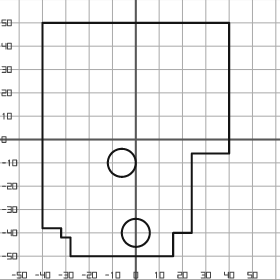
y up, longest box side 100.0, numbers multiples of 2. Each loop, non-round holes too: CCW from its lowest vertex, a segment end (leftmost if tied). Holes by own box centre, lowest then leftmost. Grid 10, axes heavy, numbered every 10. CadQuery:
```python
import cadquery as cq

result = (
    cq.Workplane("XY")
    .moveTo(-28.0, -50.0)
    .lineTo(16.0, -50.0)
    .lineTo(16.0, -40.0)
    .lineTo(24.0, -40.0)
    .lineTo(24.0, -6.0)
    .lineTo(40.0, -6.0)
    .lineTo(40.0, 50.0)
    .lineTo(-40.0, 50.0)
    .lineTo(-40.0, -38.0)
    .lineTo(-32.0, -38.0)
    .lineTo(-32.0, -42.0)
    .lineTo(-28.0, -42.0)
    .close()
    .moveTo(0.0, -40.0)
    .circle(6.0)
    .moveTo(-6.0, -10.0)
    .circle(6.0)
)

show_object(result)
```